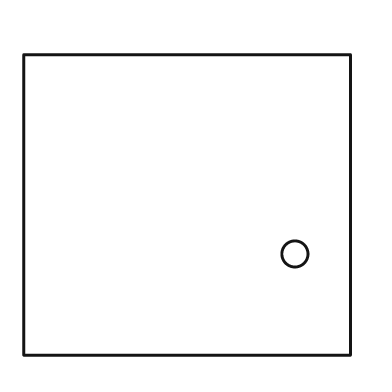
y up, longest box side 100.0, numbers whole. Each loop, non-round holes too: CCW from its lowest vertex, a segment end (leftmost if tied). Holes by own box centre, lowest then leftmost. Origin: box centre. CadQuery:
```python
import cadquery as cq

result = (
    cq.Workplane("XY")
    .moveTo(-50.0, -46.0)
    .lineTo(50.0, -46.0)
    .lineTo(50.0, 46.0)
    .lineTo(-50.0, 46.0)
    .close()
    .moveTo(33.0, -15.0)
    .circle(4.0)
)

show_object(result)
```